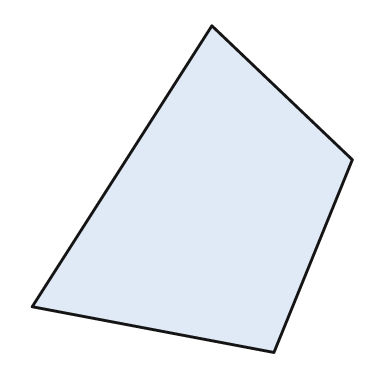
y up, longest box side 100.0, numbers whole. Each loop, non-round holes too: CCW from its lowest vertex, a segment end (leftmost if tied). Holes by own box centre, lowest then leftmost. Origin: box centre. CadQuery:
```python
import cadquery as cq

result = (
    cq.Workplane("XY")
    .moveTo(25.0, -50.0)
    .lineTo(49.0, 9.0)
    .lineTo(6.0, 50.0)
    .lineTo(-49.0, -36.0)
    .close()
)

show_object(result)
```